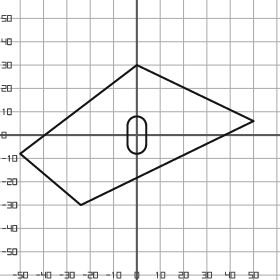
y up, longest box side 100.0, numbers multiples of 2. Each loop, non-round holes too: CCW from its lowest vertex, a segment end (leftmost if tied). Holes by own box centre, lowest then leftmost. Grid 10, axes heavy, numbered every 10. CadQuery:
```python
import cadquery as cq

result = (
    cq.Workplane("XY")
    .moveTo(-24.0, -30.0)
    .lineTo(50.0, 6.0)
    .lineTo(0.0, 30.0)
    .lineTo(-50.0, -8.0)
    .close()
    .moveTo(-4.0, -4.0)
    .threePointArc((0.0, -8.0), (4.0, -4.0))
    .lineTo(4.0, 4.0)
    .threePointArc((0.0, 8.0), (-4.0, 4.0))
    .close()
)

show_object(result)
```